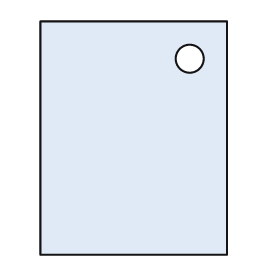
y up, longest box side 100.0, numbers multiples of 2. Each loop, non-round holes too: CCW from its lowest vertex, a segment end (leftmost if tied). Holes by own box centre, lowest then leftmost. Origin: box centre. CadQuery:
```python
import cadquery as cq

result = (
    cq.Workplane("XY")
    .moveTo(-40.0, -50.0)
    .lineTo(40.0, -50.0)
    .lineTo(40.0, 50.0)
    .lineTo(-40.0, 50.0)
    .close()
    .moveTo(24.0, 34.0)
    .circle(6.0)
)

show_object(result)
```